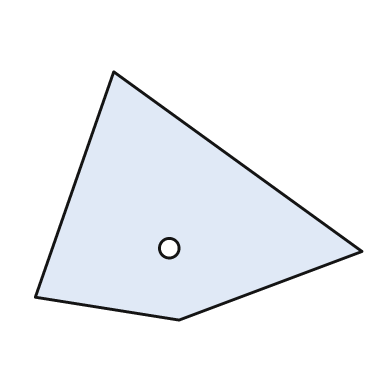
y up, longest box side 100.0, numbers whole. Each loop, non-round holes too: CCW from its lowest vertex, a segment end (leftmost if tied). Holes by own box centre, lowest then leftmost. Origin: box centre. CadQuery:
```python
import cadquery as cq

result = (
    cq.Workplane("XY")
    .moveTo(-6.0, -38.0)
    .lineTo(50.0, -17.0)
    .lineTo(-26.0, 38.0)
    .lineTo(-50.0, -31.0)
    .close()
    .moveTo(-9.0, -16.0)
    .circle(3.0)
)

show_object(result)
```